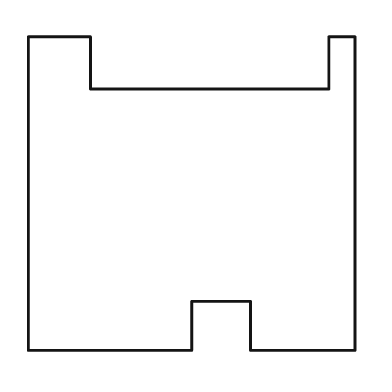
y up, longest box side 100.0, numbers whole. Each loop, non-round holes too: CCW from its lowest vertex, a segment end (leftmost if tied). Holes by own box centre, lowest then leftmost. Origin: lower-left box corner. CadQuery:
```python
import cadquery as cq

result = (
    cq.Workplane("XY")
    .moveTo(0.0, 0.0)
    .lineTo(50.0, 0.0)
    .lineTo(50.0, 15.0)
    .lineTo(68.0, 15.0)
    .lineTo(68.0, 0.0)
    .lineTo(100.0, 0.0)
    .lineTo(100.0, 96.0)
    .lineTo(92.0, 96.0)
    .lineTo(92.0, 80.0)
    .lineTo(19.0, 80.0)
    .lineTo(19.0, 96.0)
    .lineTo(0.0, 96.0)
    .close()
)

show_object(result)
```